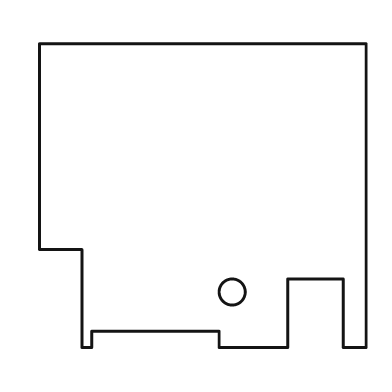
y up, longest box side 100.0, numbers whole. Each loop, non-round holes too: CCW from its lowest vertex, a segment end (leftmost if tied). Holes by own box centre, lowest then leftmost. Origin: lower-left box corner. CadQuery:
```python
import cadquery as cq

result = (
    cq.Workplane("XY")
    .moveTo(13.0, 0.0)
    .lineTo(16.0, 0.0)
    .lineTo(16.0, 5.0)
    .lineTo(55.0, 5.0)
    .lineTo(55.0, 0.0)
    .lineTo(76.0, 0.0)
    .lineTo(76.0, 21.0)
    .lineTo(93.0, 21.0)
    .lineTo(93.0, 0.0)
    .lineTo(100.0, 0.0)
    .lineTo(100.0, 93.0)
    .lineTo(0.0, 93.0)
    .lineTo(0.0, 30.0)
    .lineTo(13.0, 30.0)
    .close()
    .moveTo(59.0, 17.0)
    .circle(4.0)
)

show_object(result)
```